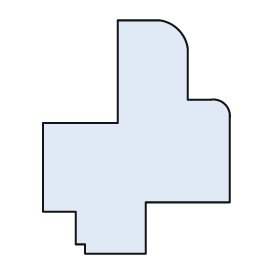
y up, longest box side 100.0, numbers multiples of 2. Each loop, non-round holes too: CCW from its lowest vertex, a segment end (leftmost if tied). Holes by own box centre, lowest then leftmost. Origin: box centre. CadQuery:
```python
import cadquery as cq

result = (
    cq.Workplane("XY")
    .moveTo(-22.0, -50.0)
    .lineTo(4.0, -50.0)
    .lineTo(4.0, -28.0)
    .lineTo(40.0, -28.0)
    .lineTo(40.0, 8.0)
    .threePointArc((38.0, 14.0), (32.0, 16.0))
    .lineTo(22.0, 16.0)
    .lineTo(22.0, 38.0)
    .threePointArc((18.0, 46.0), (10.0, 50.0))
    .lineTo(-8.0, 50.0)
    .lineTo(-8.0, 6.0)
    .lineTo(-40.0, 6.0)
    .lineTo(-40.0, -32.0)
    .lineTo(-26.0, -32.0)
    .lineTo(-26.0, -46.0)
    .lineTo(-22.0, -46.0)
    .close()
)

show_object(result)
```